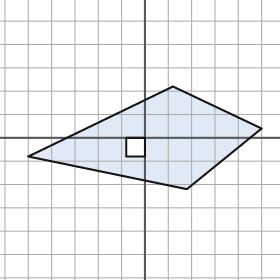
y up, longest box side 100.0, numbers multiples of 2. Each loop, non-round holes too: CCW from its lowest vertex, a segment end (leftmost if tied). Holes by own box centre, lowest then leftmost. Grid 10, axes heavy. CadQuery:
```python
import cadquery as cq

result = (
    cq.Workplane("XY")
    .moveTo(18.0, -22.0)
    .lineTo(50.0, 4.0)
    .lineTo(12.0, 22.0)
    .lineTo(-50.0, -8.0)
    .close()
    .moveTo(-8.0, -8.0)
    .lineTo(0.0, -8.0)
    .lineTo(0.0, 0.0)
    .lineTo(-8.0, 0.0)
    .close()
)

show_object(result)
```